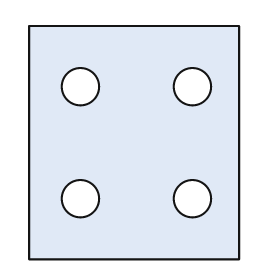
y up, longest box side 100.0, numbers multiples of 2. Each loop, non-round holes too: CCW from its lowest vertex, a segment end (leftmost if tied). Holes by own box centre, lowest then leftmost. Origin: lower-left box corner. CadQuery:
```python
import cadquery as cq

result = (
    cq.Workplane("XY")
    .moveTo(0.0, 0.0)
    .lineTo(90.0, 0.0)
    .lineTo(90.0, 100.0)
    .lineTo(0.0, 100.0)
    .close()
    .moveTo(22.0, 26.0)
    .circle(8.0)
    .moveTo(70.0, 26.0)
    .circle(8.0)
    .moveTo(22.0, 74.0)
    .circle(8.0)
    .moveTo(70.0, 74.0)
    .circle(8.0)
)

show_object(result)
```